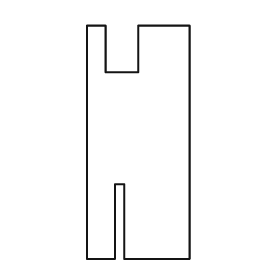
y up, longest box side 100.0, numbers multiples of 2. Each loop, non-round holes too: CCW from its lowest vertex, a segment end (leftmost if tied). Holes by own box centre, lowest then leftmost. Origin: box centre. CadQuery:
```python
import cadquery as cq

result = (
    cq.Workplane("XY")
    .moveTo(-22.0, -50.0)
    .lineTo(-10.0, -50.0)
    .lineTo(-10.0, -18.0)
    .lineTo(-6.0, -18.0)
    .lineTo(-6.0, -50.0)
    .lineTo(22.0, -50.0)
    .lineTo(22.0, 50.0)
    .lineTo(0.0, 50.0)
    .lineTo(0.0, 30.0)
    .lineTo(-14.0, 30.0)
    .lineTo(-14.0, 50.0)
    .lineTo(-22.0, 50.0)
    .close()
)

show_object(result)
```